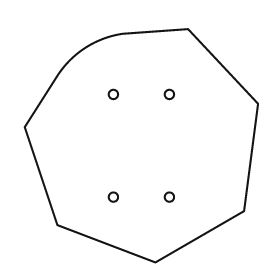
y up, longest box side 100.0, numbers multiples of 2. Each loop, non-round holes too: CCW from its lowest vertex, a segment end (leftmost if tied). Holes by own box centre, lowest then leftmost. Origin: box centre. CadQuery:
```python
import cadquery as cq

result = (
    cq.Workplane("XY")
    .moveTo(6.0, -50.0)
    .lineTo(44.0, -28.0)
    .lineTo(50.0, 18.0)
    .lineTo(20.0, 50.0)
    .lineTo(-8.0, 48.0)
    .threePointArc((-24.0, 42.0), (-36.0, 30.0))
    .lineTo(-50.0, 8.0)
    .lineTo(-36.0, -34.0)
    .close()
    .moveTo(-12.0, -22.0)
    .circle(2.0)
    .moveTo(12.0, -22.0)
    .circle(2.0)
    .moveTo(-12.0, 22.0)
    .circle(2.0)
    .moveTo(12.0, 22.0)
    .circle(2.0)
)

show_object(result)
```